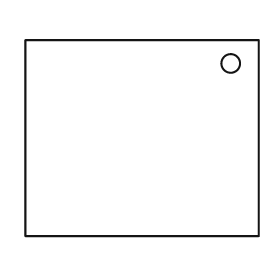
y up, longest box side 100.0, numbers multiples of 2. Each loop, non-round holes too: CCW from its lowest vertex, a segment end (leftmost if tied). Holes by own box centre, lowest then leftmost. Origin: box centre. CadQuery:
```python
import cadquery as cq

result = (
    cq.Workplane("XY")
    .moveTo(-50.0, -42.0)
    .lineTo(50.0, -42.0)
    .lineTo(50.0, 42.0)
    .lineTo(-50.0, 42.0)
    .close()
    .moveTo(38.0, 32.0)
    .circle(4.0)
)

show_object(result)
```